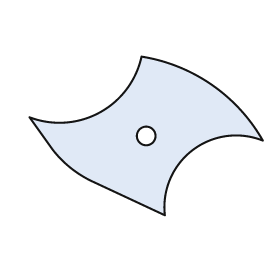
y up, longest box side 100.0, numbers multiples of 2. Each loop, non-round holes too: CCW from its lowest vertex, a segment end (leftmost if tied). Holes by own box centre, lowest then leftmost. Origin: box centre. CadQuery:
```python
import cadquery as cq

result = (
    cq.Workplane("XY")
    .moveTo(8.0, -34.0)
    .threePointArc((20.0, -6.0), (50.0, -2.0))
    .threePointArc((28.0, 22.0), (-2.0, 34.0))
    .threePointArc((-20.0, 10.0), (-50.0, 8.0))
    .lineTo(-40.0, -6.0)
    .threePointArc((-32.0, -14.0), (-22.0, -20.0))
    .close()
    .moveTo(0.0, 0.0)
    .circle(4.0)
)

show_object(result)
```